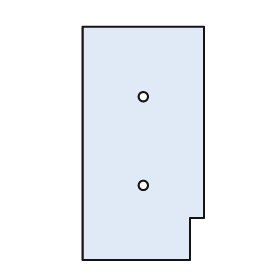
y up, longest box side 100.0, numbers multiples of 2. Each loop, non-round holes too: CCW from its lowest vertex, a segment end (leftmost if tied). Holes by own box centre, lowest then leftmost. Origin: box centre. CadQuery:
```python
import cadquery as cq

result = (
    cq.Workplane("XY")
    .moveTo(-26.0, -50.0)
    .lineTo(20.0, -50.0)
    .lineTo(20.0, -32.0)
    .lineTo(26.0, -32.0)
    .lineTo(26.0, 50.0)
    .lineTo(-26.0, 50.0)
    .close()
    .moveTo(0.0, -18.0)
    .circle(2.0)
    .moveTo(0.0, 20.0)
    .circle(2.0)
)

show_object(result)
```